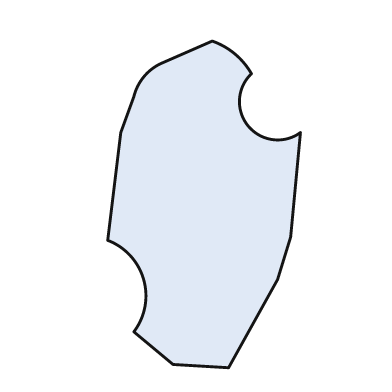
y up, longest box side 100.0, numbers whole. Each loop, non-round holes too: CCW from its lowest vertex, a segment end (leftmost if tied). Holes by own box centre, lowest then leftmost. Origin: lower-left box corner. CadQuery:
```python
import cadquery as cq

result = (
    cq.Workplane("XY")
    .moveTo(37.0, 0.0)
    .lineTo(52.0, 27.0)
    .lineTo(56.0, 40.0)
    .lineTo(59.0, 72.0)
    .threePointArc((43.0, 74.0), (44.0, 90.0))
    .threePointArc((39.0, 96.0), (32.0, 100.0))
    .lineTo(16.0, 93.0)
    .threePointArc((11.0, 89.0), (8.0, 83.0))
    .lineTo(4.0, 72.0)
    .lineTo(0.0, 39.0)
    .threePointArc((11.0, 27.0), (8.0, 11.0))
    .lineTo(20.0, 1.0)
    .close()
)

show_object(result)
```